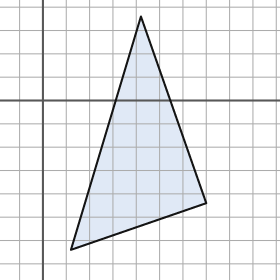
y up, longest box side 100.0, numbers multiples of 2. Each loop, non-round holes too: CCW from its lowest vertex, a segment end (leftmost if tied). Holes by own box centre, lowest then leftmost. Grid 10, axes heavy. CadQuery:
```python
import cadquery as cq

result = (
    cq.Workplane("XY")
    .moveTo(12.0, -64.0)
    .lineTo(70.0, -44.0)
    .lineTo(42.0, 36.0)
    .close()
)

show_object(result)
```